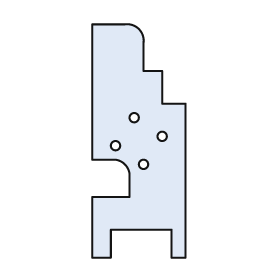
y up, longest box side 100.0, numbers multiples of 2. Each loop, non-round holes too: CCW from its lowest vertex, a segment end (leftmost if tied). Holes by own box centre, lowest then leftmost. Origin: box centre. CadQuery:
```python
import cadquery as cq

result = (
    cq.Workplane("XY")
    .moveTo(-20.0, -50.0)
    .lineTo(-12.0, -50.0)
    .lineTo(-12.0, -38.0)
    .lineTo(14.0, -38.0)
    .lineTo(14.0, -50.0)
    .lineTo(20.0, -50.0)
    .lineTo(20.0, 16.0)
    .lineTo(10.0, 16.0)
    .lineTo(10.0, 30.0)
    .lineTo(2.0, 30.0)
    .lineTo(2.0, 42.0)
    .threePointArc((0.0, 48.0), (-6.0, 50.0))
    .lineTo(-20.0, 50.0)
    .lineTo(-20.0, -8.0)
    .lineTo(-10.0, -8.0)
    .threePointArc((-6.0, -10.0), (-4.0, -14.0))
    .lineTo(-4.0, -24.0)
    .lineTo(-20.0, -24.0)
    .close()
    .moveTo(2.0, -10.0)
    .circle(2.0)
    .moveTo(-10.0, -2.0)
    .circle(2.0)
    .moveTo(10.0, 2.0)
    .circle(2.0)
    .moveTo(-2.0, 10.0)
    .circle(2.0)
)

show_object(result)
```